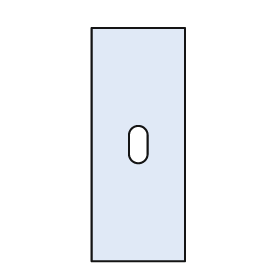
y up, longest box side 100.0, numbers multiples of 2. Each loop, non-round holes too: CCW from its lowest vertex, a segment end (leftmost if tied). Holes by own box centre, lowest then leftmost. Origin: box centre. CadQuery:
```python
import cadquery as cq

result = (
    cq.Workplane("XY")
    .moveTo(-20.0, -50.0)
    .lineTo(20.0, -50.0)
    .lineTo(20.0, 50.0)
    .lineTo(-20.0, 50.0)
    .close()
    .moveTo(-4.0, -4.0)
    .threePointArc((0.0, -8.0), (4.0, -4.0))
    .lineTo(4.0, 4.0)
    .threePointArc((0.0, 8.0), (-4.0, 4.0))
    .close()
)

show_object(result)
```